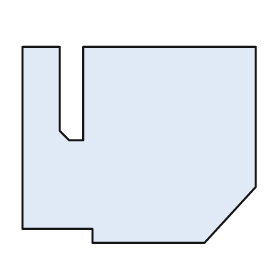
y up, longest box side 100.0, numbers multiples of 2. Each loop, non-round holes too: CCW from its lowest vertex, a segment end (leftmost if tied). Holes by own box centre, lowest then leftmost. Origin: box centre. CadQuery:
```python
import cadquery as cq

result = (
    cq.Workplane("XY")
    .moveTo(-20.0, -42.0)
    .lineTo(28.0, -42.0)
    .lineTo(50.0, -18.0)
    .lineTo(50.0, 42.0)
    .lineTo(-24.0, 42.0)
    .lineTo(-24.0, 2.0)
    .lineTo(-30.0, 2.0)
    .lineTo(-34.0, 6.0)
    .lineTo(-34.0, 42.0)
    .lineTo(-50.0, 42.0)
    .lineTo(-50.0, -36.0)
    .lineTo(-20.0, -36.0)
    .close()
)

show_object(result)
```